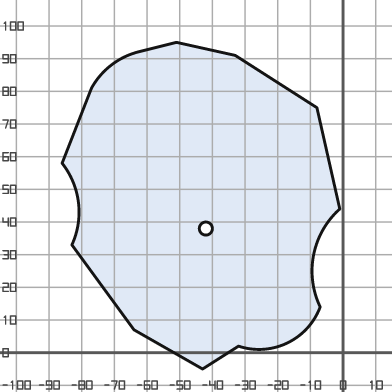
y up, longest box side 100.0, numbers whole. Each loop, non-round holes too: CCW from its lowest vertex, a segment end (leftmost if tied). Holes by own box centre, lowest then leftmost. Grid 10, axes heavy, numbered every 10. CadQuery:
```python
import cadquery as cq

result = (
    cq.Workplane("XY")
    .moveTo(-43.0, -5.0)
    .lineTo(-32.0, 2.0)
    .threePointArc((-17.0, 3.0), (-7.0, 14.0))
    .threePointArc((-9.0, 30.0), (-1.0, 44.0))
    .lineTo(-8.0, 75.0)
    .lineTo(-33.0, 91.0)
    .lineTo(-51.0, 95.0)
    .lineTo(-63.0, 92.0)
    .threePointArc((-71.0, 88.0), (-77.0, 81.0))
    .lineTo(-86.0, 58.0)
    .threePointArc((-81.0, 46.0), (-83.0, 33.0))
    .lineTo(-64.0, 7.0)
    .close()
    .moveTo(-42.0, 38.0)
    .circle(2.0)
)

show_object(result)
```